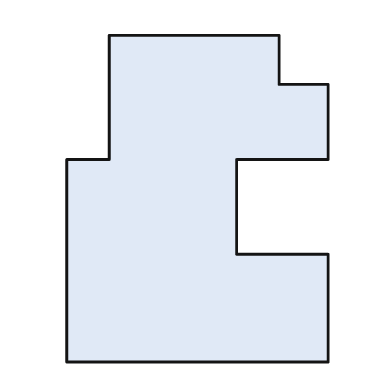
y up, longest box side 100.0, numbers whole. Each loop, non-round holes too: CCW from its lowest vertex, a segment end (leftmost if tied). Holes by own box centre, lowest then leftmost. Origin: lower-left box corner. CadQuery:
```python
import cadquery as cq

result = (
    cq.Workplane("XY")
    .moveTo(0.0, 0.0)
    .lineTo(80.0, 0.0)
    .lineTo(80.0, 33.0)
    .lineTo(52.0, 33.0)
    .lineTo(52.0, 62.0)
    .lineTo(80.0, 62.0)
    .lineTo(80.0, 85.0)
    .lineTo(65.0, 85.0)
    .lineTo(65.0, 100.0)
    .lineTo(13.0, 100.0)
    .lineTo(13.0, 62.0)
    .lineTo(0.0, 62.0)
    .close()
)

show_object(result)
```